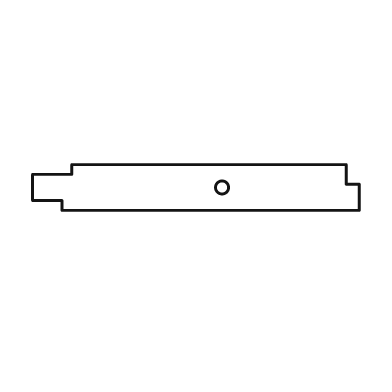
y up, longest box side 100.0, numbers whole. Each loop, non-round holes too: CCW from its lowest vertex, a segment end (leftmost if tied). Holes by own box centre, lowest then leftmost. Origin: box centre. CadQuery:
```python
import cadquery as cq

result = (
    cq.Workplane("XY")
    .moveTo(-41.0, -7.0)
    .lineTo(50.0, -7.0)
    .lineTo(50.0, 1.0)
    .lineTo(46.0, 1.0)
    .lineTo(46.0, 7.0)
    .lineTo(-38.0, 7.0)
    .lineTo(-38.0, 4.0)
    .lineTo(-50.0, 4.0)
    .lineTo(-50.0, -4.0)
    .lineTo(-41.0, -4.0)
    .close()
    .moveTo(8.0, 0.0)
    .circle(2.0)
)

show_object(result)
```